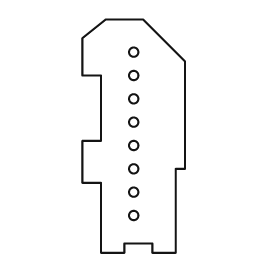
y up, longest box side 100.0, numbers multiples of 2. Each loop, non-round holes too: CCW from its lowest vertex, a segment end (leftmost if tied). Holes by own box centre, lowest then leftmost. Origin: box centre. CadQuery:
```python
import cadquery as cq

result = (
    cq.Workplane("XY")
    .moveTo(-14.0, -50.0)
    .lineTo(-4.0, -50.0)
    .lineTo(-4.0, -46.0)
    .lineTo(8.0, -46.0)
    .lineTo(8.0, -50.0)
    .lineTo(18.0, -50.0)
    .lineTo(18.0, -14.0)
    .lineTo(22.0, -14.0)
    .lineTo(22.0, 32.0)
    .lineTo(4.0, 50.0)
    .lineTo(-12.0, 50.0)
    .lineTo(-22.0, 42.0)
    .lineTo(-22.0, 26.0)
    .lineTo(-14.0, 26.0)
    .lineTo(-14.0, -2.0)
    .lineTo(-22.0, -2.0)
    .lineTo(-22.0, -20.0)
    .lineTo(-14.0, -20.0)
    .close()
    .moveTo(0.0, -34.0)
    .circle(2.0)
    .moveTo(0.0, -24.0)
    .circle(2.0)
    .moveTo(0.0, -14.0)
    .circle(2.0)
    .moveTo(0.0, -4.0)
    .circle(2.0)
    .moveTo(0.0, 6.0)
    .circle(2.0)
    .moveTo(0.0, 16.0)
    .circle(2.0)
    .moveTo(0.0, 26.0)
    .circle(2.0)
    .moveTo(0.0, 36.0)
    .circle(2.0)
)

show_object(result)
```